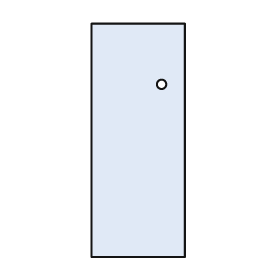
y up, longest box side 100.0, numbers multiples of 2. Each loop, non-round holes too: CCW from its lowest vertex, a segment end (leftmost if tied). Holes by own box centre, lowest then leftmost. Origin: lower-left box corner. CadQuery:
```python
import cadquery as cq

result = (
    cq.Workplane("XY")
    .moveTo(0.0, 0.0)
    .lineTo(40.0, 0.0)
    .lineTo(40.0, 100.0)
    .lineTo(0.0, 100.0)
    .close()
    .moveTo(30.0, 74.0)
    .circle(2.0)
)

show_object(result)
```